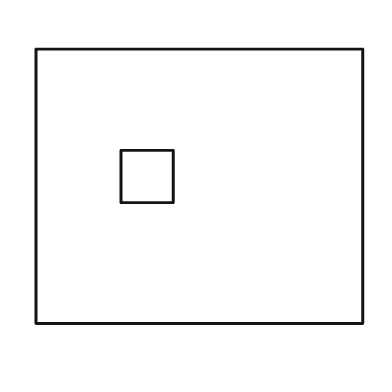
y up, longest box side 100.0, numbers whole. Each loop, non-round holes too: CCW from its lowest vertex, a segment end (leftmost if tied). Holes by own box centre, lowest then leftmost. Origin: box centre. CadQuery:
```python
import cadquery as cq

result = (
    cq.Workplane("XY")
    .moveTo(-50.0, -42.0)
    .lineTo(50.0, -42.0)
    .lineTo(50.0, 42.0)
    .lineTo(-50.0, 42.0)
    .close()
    .moveTo(-24.0, -5.0)
    .lineTo(-8.0, -5.0)
    .lineTo(-8.0, 11.0)
    .lineTo(-24.0, 11.0)
    .close()
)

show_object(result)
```